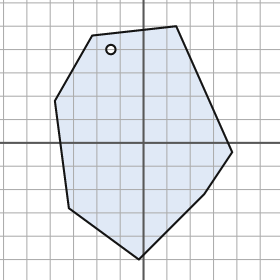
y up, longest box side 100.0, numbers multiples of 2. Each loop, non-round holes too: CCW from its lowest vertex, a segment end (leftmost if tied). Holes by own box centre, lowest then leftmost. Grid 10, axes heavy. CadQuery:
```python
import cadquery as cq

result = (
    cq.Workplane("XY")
    .moveTo(-2.0, -50.0)
    .lineTo(26.0, -22.0)
    .lineTo(38.0, -4.0)
    .lineTo(14.0, 50.0)
    .lineTo(-22.0, 46.0)
    .lineTo(-38.0, 18.0)
    .lineTo(-32.0, -28.0)
    .close()
    .moveTo(-14.0, 40.0)
    .circle(2.0)
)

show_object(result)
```